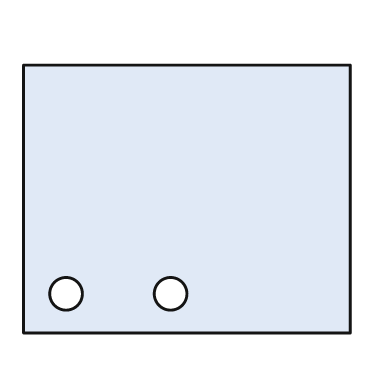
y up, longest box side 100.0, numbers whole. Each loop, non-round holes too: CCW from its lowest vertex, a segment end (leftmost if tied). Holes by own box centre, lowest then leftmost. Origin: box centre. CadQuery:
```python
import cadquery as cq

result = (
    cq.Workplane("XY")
    .moveTo(-50.0, -41.0)
    .lineTo(50.0, -41.0)
    .lineTo(50.0, 41.0)
    .lineTo(-50.0, 41.0)
    .close()
    .moveTo(-37.0, -29.0)
    .circle(5.0)
    .moveTo(-5.0, -29.0)
    .circle(5.0)
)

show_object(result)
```